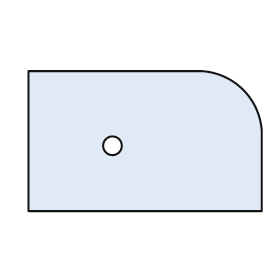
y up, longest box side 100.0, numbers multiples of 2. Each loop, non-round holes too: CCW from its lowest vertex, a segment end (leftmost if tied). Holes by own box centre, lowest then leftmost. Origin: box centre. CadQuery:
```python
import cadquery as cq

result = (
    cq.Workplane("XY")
    .moveTo(-50.0, -30.0)
    .lineTo(50.0, -30.0)
    .lineTo(50.0, 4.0)
    .threePointArc((42.0, 22.0), (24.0, 30.0))
    .lineTo(-50.0, 30.0)
    .close()
    .moveTo(-14.0, -2.0)
    .circle(4.0)
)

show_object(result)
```